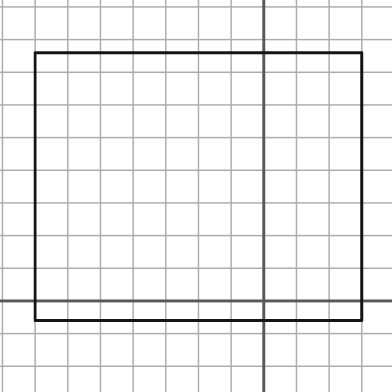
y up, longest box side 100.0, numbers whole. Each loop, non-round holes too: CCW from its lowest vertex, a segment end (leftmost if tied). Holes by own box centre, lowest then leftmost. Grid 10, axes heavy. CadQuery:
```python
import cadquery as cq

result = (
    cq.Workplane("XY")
    .moveTo(-70.0, -6.0)
    .lineTo(30.0, -6.0)
    .lineTo(30.0, 76.0)
    .lineTo(-70.0, 76.0)
    .close()
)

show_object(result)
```